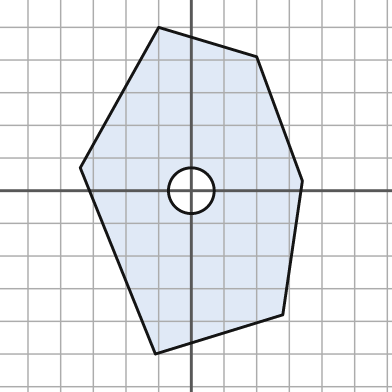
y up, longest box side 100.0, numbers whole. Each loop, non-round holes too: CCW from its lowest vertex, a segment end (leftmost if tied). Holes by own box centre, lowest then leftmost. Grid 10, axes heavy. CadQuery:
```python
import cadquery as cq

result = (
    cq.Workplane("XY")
    .moveTo(-11.0, -50.0)
    .lineTo(28.0, -38.0)
    .lineTo(34.0, 3.0)
    .lineTo(20.0, 41.0)
    .lineTo(-10.0, 50.0)
    .lineTo(-34.0, 7.0)
    .close()
    .moveTo(0.0, 0.0)
    .circle(7.0)
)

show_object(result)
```